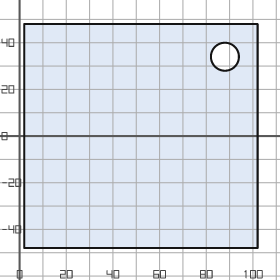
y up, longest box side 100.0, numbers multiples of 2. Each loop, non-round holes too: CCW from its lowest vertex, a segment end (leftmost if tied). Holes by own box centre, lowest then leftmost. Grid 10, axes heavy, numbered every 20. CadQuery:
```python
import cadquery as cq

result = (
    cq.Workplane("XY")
    .moveTo(2.0, -48.0)
    .lineTo(102.0, -48.0)
    .lineTo(102.0, 48.0)
    .lineTo(2.0, 48.0)
    .close()
    .moveTo(88.0, 34.0)
    .circle(6.0)
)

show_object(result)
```